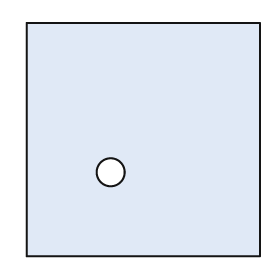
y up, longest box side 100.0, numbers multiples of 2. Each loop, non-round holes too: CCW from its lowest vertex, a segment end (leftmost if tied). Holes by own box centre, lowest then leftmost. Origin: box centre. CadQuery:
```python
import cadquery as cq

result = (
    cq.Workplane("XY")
    .moveTo(-50.0, -50.0)
    .lineTo(50.0, -50.0)
    .lineTo(50.0, 50.0)
    .lineTo(-50.0, 50.0)
    .close()
    .moveTo(-14.0, -14.0)
    .circle(6.0)
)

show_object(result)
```